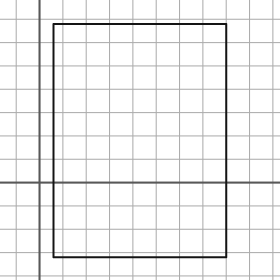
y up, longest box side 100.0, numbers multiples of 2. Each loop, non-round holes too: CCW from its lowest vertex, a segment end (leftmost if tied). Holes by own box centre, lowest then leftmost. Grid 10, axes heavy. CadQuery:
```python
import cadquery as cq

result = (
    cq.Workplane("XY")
    .moveTo(6.0, -32.0)
    .lineTo(80.0, -32.0)
    .lineTo(80.0, 68.0)
    .lineTo(6.0, 68.0)
    .close()
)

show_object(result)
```